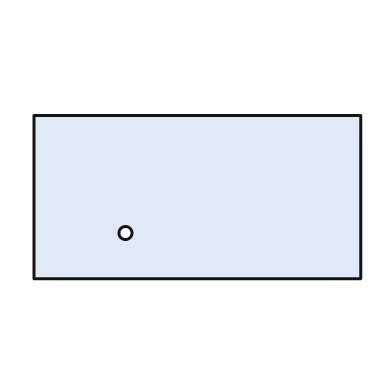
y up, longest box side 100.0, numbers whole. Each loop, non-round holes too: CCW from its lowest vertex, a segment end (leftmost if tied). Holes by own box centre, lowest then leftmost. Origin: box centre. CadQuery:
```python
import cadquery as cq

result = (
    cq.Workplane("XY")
    .moveTo(-50.0, -25.0)
    .lineTo(50.0, -25.0)
    .lineTo(50.0, 25.0)
    .lineTo(-50.0, 25.0)
    .close()
    .moveTo(-22.0, -11.0)
    .circle(2.0)
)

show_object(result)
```